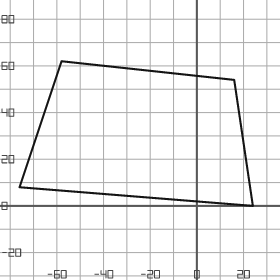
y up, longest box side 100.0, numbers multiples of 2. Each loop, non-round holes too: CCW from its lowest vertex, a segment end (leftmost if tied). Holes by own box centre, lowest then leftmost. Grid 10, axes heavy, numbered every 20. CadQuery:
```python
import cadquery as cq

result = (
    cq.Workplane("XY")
    .moveTo(24.0, 0.0)
    .lineTo(16.0, 54.0)
    .lineTo(-58.0, 62.0)
    .lineTo(-76.0, 8.0)
    .close()
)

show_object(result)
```